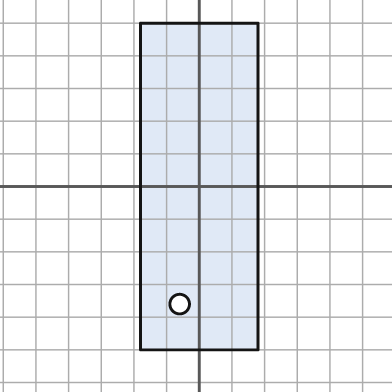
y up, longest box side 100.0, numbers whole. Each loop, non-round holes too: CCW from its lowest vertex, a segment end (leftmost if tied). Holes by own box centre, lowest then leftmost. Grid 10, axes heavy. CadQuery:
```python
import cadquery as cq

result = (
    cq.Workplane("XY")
    .moveTo(-18.0, -50.0)
    .lineTo(18.0, -50.0)
    .lineTo(18.0, 50.0)
    .lineTo(-18.0, 50.0)
    .close()
    .moveTo(-6.0, -36.0)
    .circle(3.0)
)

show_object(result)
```